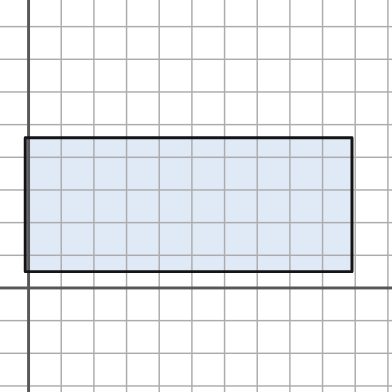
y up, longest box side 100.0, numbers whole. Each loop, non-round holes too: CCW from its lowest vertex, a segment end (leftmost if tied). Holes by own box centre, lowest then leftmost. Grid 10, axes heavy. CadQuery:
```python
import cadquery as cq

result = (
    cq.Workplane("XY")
    .moveTo(-1.0, 5.0)
    .lineTo(99.0, 5.0)
    .lineTo(99.0, 46.0)
    .lineTo(-1.0, 46.0)
    .close()
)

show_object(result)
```